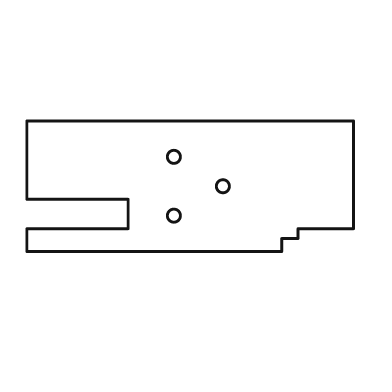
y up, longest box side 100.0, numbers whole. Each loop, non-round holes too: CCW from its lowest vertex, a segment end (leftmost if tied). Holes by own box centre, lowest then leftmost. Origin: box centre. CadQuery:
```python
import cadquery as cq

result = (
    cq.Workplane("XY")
    .moveTo(-50.0, -20.0)
    .lineTo(28.0, -20.0)
    .lineTo(28.0, -16.0)
    .lineTo(33.0, -16.0)
    .lineTo(33.0, -13.0)
    .lineTo(50.0, -13.0)
    .lineTo(50.0, 20.0)
    .lineTo(-50.0, 20.0)
    .lineTo(-50.0, -4.0)
    .lineTo(-19.0, -4.0)
    .lineTo(-19.0, -13.0)
    .lineTo(-50.0, -13.0)
    .close()
    .moveTo(-5.0, -9.0)
    .circle(2.0)
    .moveTo(10.0, 0.0)
    .circle(2.0)
    .moveTo(-5.0, 9.0)
    .circle(2.0)
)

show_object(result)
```